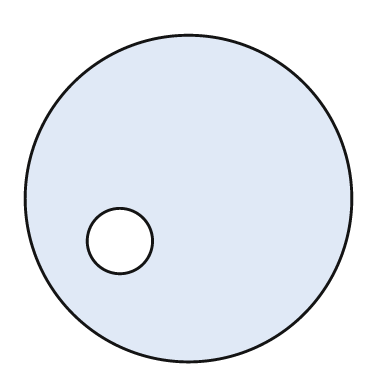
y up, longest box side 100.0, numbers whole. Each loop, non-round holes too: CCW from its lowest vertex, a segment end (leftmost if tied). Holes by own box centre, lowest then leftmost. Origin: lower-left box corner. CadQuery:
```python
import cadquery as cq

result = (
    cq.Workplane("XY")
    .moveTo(50.0, 50.0)
    .circle(50.0)
    .moveTo(29.0, 37.0)
    .circle(10.0)
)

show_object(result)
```